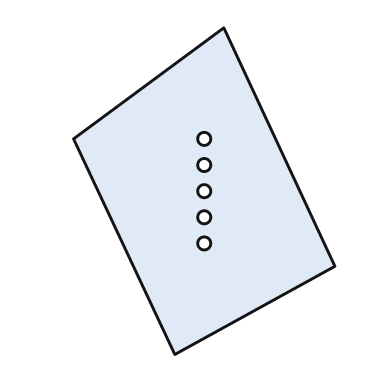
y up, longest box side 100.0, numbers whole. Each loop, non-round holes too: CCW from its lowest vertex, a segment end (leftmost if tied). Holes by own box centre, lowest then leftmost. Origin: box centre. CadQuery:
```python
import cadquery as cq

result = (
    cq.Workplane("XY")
    .moveTo(-9.0, -50.0)
    .lineTo(40.0, -23.0)
    .lineTo(6.0, 50.0)
    .lineTo(-40.0, 16.0)
    .close()
    .moveTo(0.0, -16.0)
    .circle(2.0)
    .moveTo(0.0, -8.0)
    .circle(2.0)
    .moveTo(0.0, 0.0)
    .circle(2.0)
    .moveTo(0.0, 8.0)
    .circle(2.0)
    .moveTo(0.0, 16.0)
    .circle(2.0)
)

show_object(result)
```